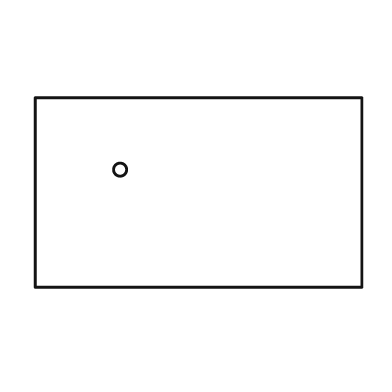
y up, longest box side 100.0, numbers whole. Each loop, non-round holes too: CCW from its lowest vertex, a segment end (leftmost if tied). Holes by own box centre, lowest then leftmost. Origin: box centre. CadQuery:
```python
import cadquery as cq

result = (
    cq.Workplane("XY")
    .moveTo(-50.0, -29.0)
    .lineTo(50.0, -29.0)
    .lineTo(50.0, 29.0)
    .lineTo(-50.0, 29.0)
    .close()
    .moveTo(-24.0, 7.0)
    .circle(2.0)
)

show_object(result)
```